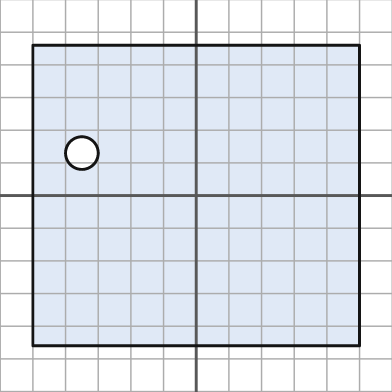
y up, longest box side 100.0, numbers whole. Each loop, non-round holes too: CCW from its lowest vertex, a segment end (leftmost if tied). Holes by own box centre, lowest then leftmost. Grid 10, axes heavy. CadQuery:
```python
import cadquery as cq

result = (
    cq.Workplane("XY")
    .moveTo(-50.0, -46.0)
    .lineTo(50.0, -46.0)
    .lineTo(50.0, 46.0)
    .lineTo(-50.0, 46.0)
    .close()
    .moveTo(-35.0, 13.0)
    .circle(5.0)
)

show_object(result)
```